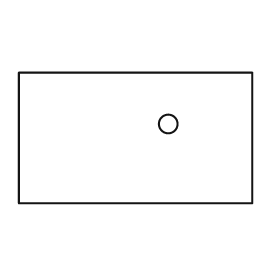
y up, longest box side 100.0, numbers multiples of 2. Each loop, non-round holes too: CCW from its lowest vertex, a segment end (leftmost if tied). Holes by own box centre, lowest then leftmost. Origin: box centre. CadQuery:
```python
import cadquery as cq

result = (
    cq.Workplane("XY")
    .moveTo(-50.0, -28.0)
    .lineTo(50.0, -28.0)
    .lineTo(50.0, 28.0)
    .lineTo(-50.0, 28.0)
    .close()
    .moveTo(14.0, 6.0)
    .circle(4.0)
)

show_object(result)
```